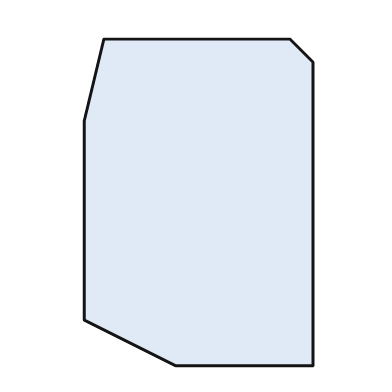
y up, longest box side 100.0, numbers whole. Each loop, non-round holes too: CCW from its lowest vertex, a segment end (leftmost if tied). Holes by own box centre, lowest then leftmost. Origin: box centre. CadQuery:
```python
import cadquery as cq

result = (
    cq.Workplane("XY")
    .moveTo(-7.0, -50.0)
    .lineTo(35.0, -50.0)
    .lineTo(35.0, 43.0)
    .lineTo(28.0, 50.0)
    .lineTo(-29.0, 50.0)
    .lineTo(-35.0, 25.0)
    .lineTo(-35.0, -36.0)
    .close()
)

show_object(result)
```